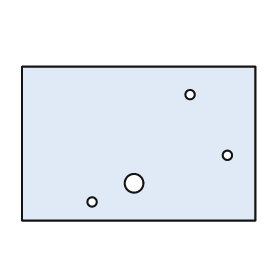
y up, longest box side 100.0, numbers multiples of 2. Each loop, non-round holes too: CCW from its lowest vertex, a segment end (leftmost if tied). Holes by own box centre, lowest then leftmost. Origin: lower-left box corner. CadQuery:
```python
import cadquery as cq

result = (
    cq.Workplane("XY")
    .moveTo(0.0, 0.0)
    .lineTo(100.0, 0.0)
    .lineTo(100.0, 66.0)
    .lineTo(0.0, 66.0)
    .close()
    .moveTo(30.0, 8.0)
    .circle(2.0)
    .moveTo(48.0, 16.0)
    .circle(4.0)
    .moveTo(88.0, 28.0)
    .circle(2.0)
    .moveTo(72.0, 54.0)
    .circle(2.0)
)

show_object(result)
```